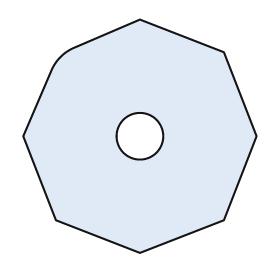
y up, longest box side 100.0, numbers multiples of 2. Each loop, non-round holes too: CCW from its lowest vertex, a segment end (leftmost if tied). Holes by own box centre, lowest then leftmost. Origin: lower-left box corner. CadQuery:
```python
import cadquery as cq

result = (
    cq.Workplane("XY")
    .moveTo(50.0, 0.0)
    .lineTo(86.0, 14.0)
    .lineTo(100.0, 50.0)
    .lineTo(86.0, 86.0)
    .lineTo(50.0, 100.0)
    .lineTo(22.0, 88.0)
    .threePointArc((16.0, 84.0), (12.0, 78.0))
    .lineTo(0.0, 50.0)
    .lineTo(14.0, 14.0)
    .close()
    .moveTo(50.0, 50.0)
    .circle(10.0)
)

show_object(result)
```